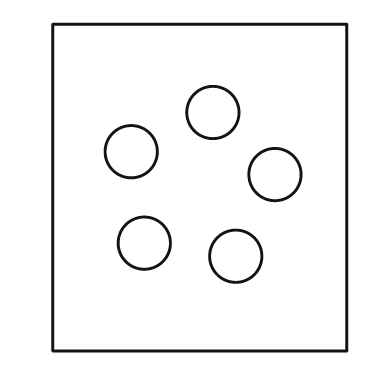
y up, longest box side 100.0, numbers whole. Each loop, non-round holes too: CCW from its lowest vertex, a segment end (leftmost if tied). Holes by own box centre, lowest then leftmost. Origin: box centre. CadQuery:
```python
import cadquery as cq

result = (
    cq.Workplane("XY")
    .moveTo(-45.0, -50.0)
    .lineTo(45.0, -50.0)
    .lineTo(45.0, 50.0)
    .lineTo(-45.0, 50.0)
    .close()
    .moveTo(11.0, -21.0)
    .circle(8.0)
    .moveTo(-17.0, -17.0)
    .circle(8.0)
    .moveTo(23.0, 4.0)
    .circle(8.0)
    .moveTo(-21.0, 11.0)
    .circle(8.0)
    .moveTo(4.0, 23.0)
    .circle(8.0)
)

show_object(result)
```